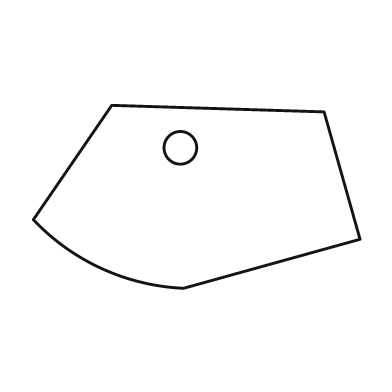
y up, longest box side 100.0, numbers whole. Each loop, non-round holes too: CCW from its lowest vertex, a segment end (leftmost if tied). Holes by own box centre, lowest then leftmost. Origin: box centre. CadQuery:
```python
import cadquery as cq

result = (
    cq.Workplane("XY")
    .moveTo(-4.0, -28.0)
    .lineTo(50.0, -13.0)
    .lineTo(39.0, 26.0)
    .lineTo(-26.0, 28.0)
    .lineTo(-50.0, -7.0)
    .threePointArc((-29.0, -22.0), (-4.0, -28.0))
    .close()
    .moveTo(-5.0, 15.0)
    .circle(5.0)
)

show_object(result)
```